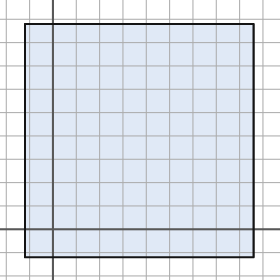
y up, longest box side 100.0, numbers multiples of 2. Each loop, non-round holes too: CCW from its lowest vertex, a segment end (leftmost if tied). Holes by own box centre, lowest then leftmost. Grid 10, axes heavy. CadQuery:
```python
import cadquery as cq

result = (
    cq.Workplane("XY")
    .moveTo(-12.0, -12.0)
    .lineTo(86.0, -12.0)
    .lineTo(86.0, 88.0)
    .lineTo(-12.0, 88.0)
    .close()
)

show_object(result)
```